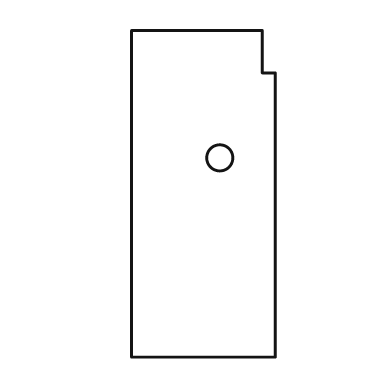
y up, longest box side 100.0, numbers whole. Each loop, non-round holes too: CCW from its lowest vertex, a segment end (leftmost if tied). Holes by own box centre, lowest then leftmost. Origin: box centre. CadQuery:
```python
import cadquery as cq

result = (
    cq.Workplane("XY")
    .moveTo(-22.0, -50.0)
    .lineTo(22.0, -50.0)
    .lineTo(22.0, 37.0)
    .lineTo(18.0, 37.0)
    .lineTo(18.0, 50.0)
    .lineTo(-22.0, 50.0)
    .close()
    .moveTo(5.0, 11.0)
    .circle(4.0)
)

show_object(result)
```